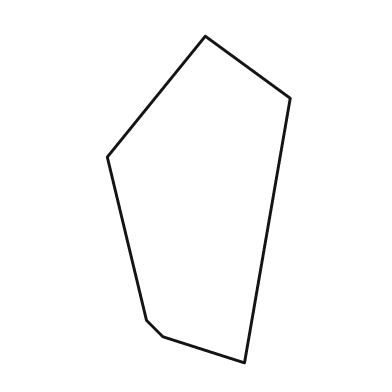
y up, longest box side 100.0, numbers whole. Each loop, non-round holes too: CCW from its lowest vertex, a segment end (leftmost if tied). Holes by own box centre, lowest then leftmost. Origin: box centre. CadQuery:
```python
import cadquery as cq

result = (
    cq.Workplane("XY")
    .moveTo(14.0, -50.0)
    .lineTo(28.0, 31.0)
    .lineTo(2.0, 50.0)
    .lineTo(-28.0, 13.0)
    .lineTo(-16.0, -37.0)
    .lineTo(-11.0, -42.0)
    .close()
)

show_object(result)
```